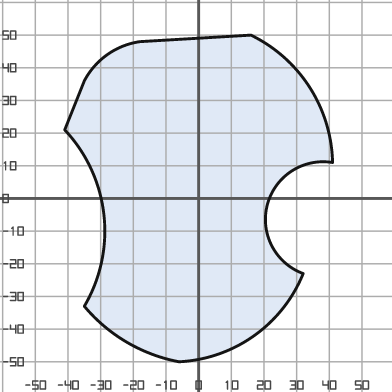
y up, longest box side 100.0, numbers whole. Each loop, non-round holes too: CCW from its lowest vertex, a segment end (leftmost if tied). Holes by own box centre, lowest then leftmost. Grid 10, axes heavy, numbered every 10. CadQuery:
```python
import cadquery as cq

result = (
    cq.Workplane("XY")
    .moveTo(-6.0, -50.0)
    .threePointArc((17.0, -42.0), (32.0, -23.0))
    .threePointArc((21.0, -2.0), (41.0, 11.0))
    .threePointArc((34.0, 34.0), (16.0, 50.0))
    .lineTo(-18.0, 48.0)
    .threePointArc((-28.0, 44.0), (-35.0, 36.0))
    .lineTo(-41.0, 21.0)
    .threePointArc((-29.0, -5.0), (-35.0, -33.0))
    .threePointArc((-22.0, -44.0), (-6.0, -50.0))
    .close()
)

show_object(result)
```